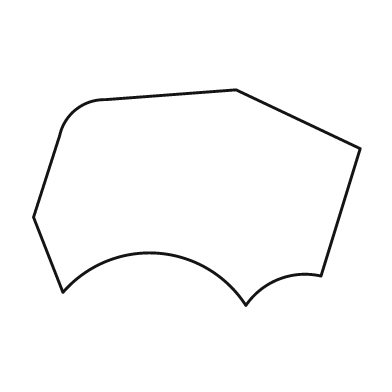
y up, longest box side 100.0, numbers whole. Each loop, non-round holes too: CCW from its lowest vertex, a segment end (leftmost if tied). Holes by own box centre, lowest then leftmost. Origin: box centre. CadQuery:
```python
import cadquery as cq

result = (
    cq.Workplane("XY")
    .moveTo(15.0, -33.0)
    .threePointArc((25.0, -25.0), (38.0, -24.0))
    .lineTo(50.0, 15.0)
    .lineTo(12.0, 33.0)
    .lineTo(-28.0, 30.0)
    .threePointArc((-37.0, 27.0), (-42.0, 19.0))
    .lineTo(-50.0, -6.0)
    .lineTo(-41.0, -29.0)
    .threePointArc((-12.0, -17.0), (15.0, -33.0))
    .close()
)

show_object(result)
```